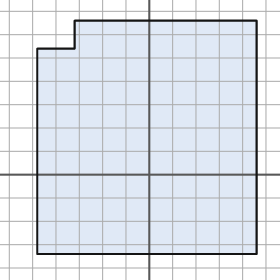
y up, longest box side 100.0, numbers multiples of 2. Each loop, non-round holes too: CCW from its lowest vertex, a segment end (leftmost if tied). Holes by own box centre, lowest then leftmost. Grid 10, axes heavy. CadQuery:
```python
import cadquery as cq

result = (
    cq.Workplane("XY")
    .moveTo(-48.0, -34.0)
    .lineTo(46.0, -34.0)
    .lineTo(46.0, 66.0)
    .lineTo(-32.0, 66.0)
    .lineTo(-32.0, 54.0)
    .lineTo(-48.0, 54.0)
    .close()
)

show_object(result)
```